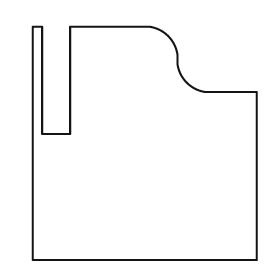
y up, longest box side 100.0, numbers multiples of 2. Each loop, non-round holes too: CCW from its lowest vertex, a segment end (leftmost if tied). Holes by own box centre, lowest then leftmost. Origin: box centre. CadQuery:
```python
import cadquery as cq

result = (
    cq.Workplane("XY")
    .moveTo(-48.0, -50.0)
    .lineTo(48.0, -50.0)
    .lineTo(48.0, 22.0)
    .lineTo(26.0, 22.0)
    .threePointArc((18.0, 26.0), (14.0, 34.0))
    .lineTo(14.0, 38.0)
    .threePointArc((10.0, 46.0), (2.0, 50.0))
    .lineTo(-32.0, 50.0)
    .lineTo(-32.0, 4.0)
    .lineTo(-44.0, 4.0)
    .lineTo(-44.0, 50.0)
    .lineTo(-48.0, 50.0)
    .close()
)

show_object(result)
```